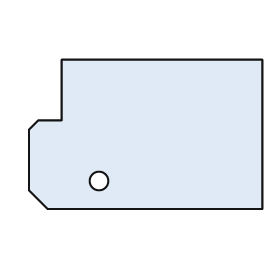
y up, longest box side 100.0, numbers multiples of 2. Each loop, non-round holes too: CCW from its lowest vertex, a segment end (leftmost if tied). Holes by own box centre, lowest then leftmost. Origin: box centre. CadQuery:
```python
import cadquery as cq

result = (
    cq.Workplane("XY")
    .moveTo(-42.0, -32.0)
    .lineTo(50.0, -32.0)
    .lineTo(50.0, 32.0)
    .lineTo(-36.0, 32.0)
    .lineTo(-36.0, 6.0)
    .lineTo(-46.0, 6.0)
    .lineTo(-50.0, 2.0)
    .lineTo(-50.0, -24.0)
    .close()
    .moveTo(-20.0, -20.0)
    .circle(4.0)
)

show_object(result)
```